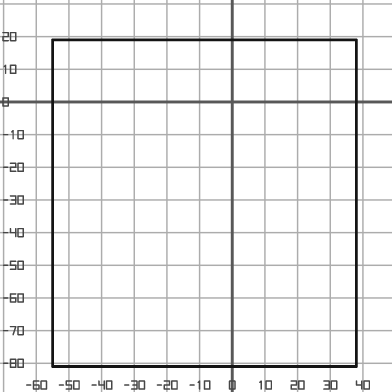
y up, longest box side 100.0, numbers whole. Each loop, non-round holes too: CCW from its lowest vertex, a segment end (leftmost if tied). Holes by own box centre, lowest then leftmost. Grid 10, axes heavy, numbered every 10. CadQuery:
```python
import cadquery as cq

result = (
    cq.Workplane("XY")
    .moveTo(-55.0, -81.0)
    .lineTo(38.0, -81.0)
    .lineTo(38.0, 19.0)
    .lineTo(-55.0, 19.0)
    .close()
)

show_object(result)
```